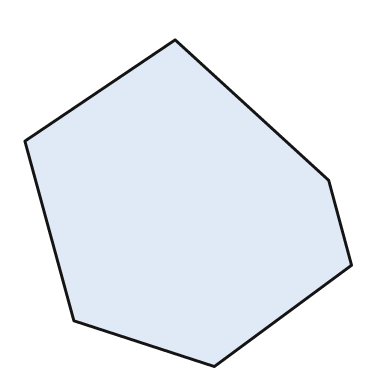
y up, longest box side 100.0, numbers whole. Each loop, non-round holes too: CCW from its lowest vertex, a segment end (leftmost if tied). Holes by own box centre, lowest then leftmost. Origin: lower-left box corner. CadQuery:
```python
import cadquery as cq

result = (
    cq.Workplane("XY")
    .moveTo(58.0, 0.0)
    .lineTo(100.0, 31.0)
    .lineTo(93.0, 57.0)
    .lineTo(46.0, 100.0)
    .lineTo(0.0, 69.0)
    .lineTo(15.0, 14.0)
    .close()
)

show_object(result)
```